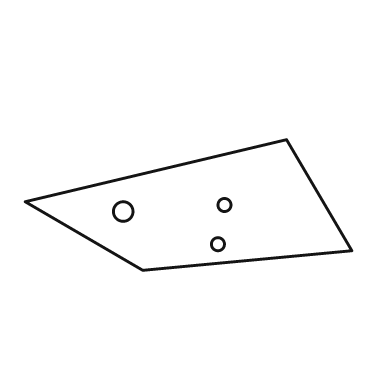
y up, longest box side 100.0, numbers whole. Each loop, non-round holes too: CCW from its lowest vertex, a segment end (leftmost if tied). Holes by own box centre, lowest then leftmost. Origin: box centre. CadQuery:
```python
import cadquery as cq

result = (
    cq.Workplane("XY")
    .moveTo(-14.0, -20.0)
    .lineTo(50.0, -14.0)
    .lineTo(30.0, 20.0)
    .lineTo(-50.0, 1.0)
    .close()
    .moveTo(9.0, -12.0)
    .circle(2.0)
    .moveTo(-20.0, -2.0)
    .circle(3.0)
    .moveTo(11.0, 0.0)
    .circle(2.0)
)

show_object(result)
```